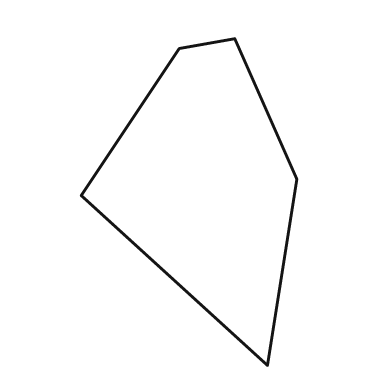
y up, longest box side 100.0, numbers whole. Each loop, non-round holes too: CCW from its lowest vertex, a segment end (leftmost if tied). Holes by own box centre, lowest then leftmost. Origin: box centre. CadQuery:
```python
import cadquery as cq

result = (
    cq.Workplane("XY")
    .moveTo(24.0, -50.0)
    .lineTo(33.0, 7.0)
    .lineTo(14.0, 50.0)
    .lineTo(-3.0, 47.0)
    .lineTo(-33.0, 2.0)
    .close()
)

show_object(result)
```